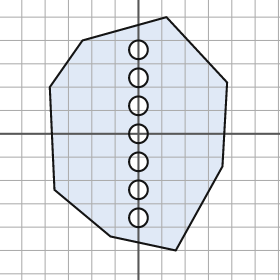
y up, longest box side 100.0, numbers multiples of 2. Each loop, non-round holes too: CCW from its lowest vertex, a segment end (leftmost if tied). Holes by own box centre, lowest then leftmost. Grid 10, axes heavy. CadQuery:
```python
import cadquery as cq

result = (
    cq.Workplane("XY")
    .moveTo(16.0, -50.0)
    .lineTo(36.0, -14.0)
    .lineTo(38.0, 22.0)
    .lineTo(12.0, 50.0)
    .lineTo(-24.0, 40.0)
    .lineTo(-38.0, 20.0)
    .lineTo(-36.0, -24.0)
    .lineTo(-12.0, -44.0)
    .close()
    .moveTo(0.0, -36.0)
    .circle(4.0)
    .moveTo(0.0, -24.0)
    .circle(4.0)
    .moveTo(0.0, -12.0)
    .circle(4.0)
    .moveTo(0.0, 0.0)
    .circle(4.0)
    .moveTo(0.0, 12.0)
    .circle(4.0)
    .moveTo(0.0, 24.0)
    .circle(4.0)
    .moveTo(0.0, 36.0)
    .circle(4.0)
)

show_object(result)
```